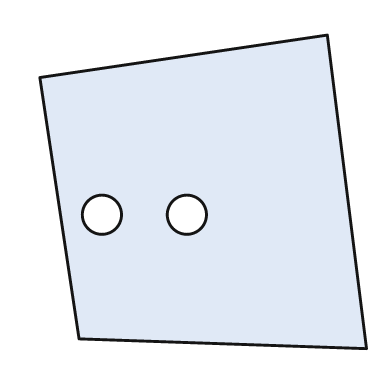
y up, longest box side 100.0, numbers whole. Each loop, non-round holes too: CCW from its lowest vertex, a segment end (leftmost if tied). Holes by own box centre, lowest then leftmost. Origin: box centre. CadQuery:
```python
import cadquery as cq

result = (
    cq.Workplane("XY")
    .moveTo(50.0, -48.0)
    .lineTo(38.0, 48.0)
    .lineTo(-50.0, 35.0)
    .lineTo(-38.0, -45.0)
    .close()
    .moveTo(-31.0, -7.0)
    .circle(6.0)
    .moveTo(-5.0, -7.0)
    .circle(6.0)
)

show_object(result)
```